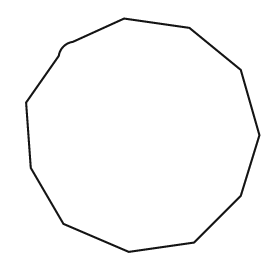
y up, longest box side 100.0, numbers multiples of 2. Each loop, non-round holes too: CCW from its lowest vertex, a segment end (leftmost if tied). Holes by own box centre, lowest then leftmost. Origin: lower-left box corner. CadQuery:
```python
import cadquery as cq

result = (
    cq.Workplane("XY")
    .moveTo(44.0, 0.0)
    .lineTo(72.0, 4.0)
    .lineTo(92.0, 24.0)
    .lineTo(100.0, 50.0)
    .lineTo(92.0, 78.0)
    .lineTo(70.0, 96.0)
    .lineTo(42.0, 100.0)
    .lineTo(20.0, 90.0)
    .threePointArc((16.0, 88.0), (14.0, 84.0))
    .lineTo(0.0, 64.0)
    .lineTo(2.0, 36.0)
    .lineTo(16.0, 12.0)
    .close()
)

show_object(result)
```